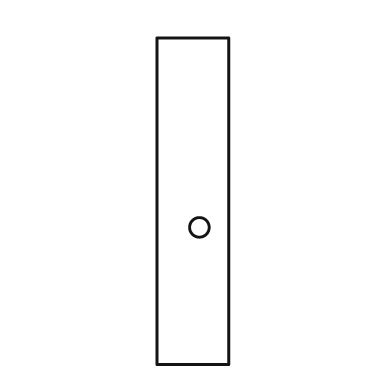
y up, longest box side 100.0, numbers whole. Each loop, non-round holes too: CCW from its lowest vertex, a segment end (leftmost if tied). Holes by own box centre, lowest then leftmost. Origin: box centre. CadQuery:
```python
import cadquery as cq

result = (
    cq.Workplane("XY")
    .moveTo(-11.0, -50.0)
    .lineTo(11.0, -50.0)
    .lineTo(11.0, 50.0)
    .lineTo(-11.0, 50.0)
    .close()
    .moveTo(2.0, -8.0)
    .circle(3.0)
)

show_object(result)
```